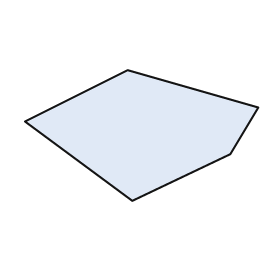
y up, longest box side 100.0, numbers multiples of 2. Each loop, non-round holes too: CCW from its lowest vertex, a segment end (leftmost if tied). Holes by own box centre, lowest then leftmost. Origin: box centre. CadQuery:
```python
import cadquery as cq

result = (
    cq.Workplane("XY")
    .moveTo(-4.0, -28.0)
    .lineTo(38.0, -8.0)
    .lineTo(50.0, 12.0)
    .lineTo(-6.0, 28.0)
    .lineTo(-50.0, 6.0)
    .close()
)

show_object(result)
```